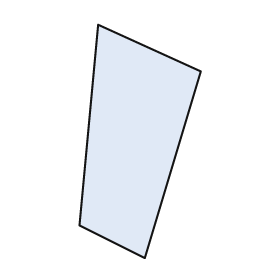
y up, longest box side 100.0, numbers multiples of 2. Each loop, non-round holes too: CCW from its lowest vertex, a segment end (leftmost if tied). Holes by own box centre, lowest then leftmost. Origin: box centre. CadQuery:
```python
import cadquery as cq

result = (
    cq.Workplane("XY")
    .moveTo(2.0, -50.0)
    .lineTo(26.0, 30.0)
    .lineTo(-18.0, 50.0)
    .lineTo(-26.0, -36.0)
    .close()
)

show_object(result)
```